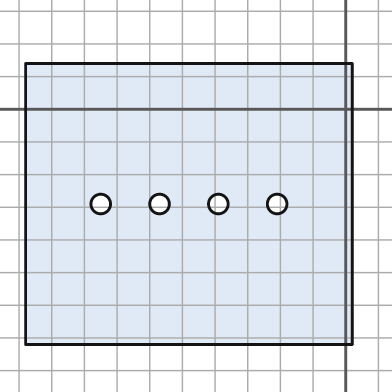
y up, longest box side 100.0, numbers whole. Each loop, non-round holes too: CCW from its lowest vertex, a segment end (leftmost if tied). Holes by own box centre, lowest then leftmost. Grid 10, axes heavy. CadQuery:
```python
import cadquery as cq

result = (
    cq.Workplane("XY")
    .moveTo(-98.0, -72.0)
    .lineTo(2.0, -72.0)
    .lineTo(2.0, 14.0)
    .lineTo(-98.0, 14.0)
    .close()
    .moveTo(-75.0, -29.0)
    .circle(3.0)
    .moveTo(-57.0, -29.0)
    .circle(3.0)
    .moveTo(-39.0, -29.0)
    .circle(3.0)
    .moveTo(-21.0, -29.0)
    .circle(3.0)
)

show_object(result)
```